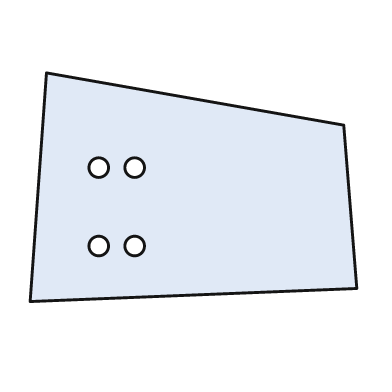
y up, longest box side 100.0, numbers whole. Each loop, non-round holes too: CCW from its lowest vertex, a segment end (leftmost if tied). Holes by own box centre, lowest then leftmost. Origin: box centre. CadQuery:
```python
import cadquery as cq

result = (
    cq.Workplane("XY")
    .moveTo(-50.0, -35.0)
    .lineTo(50.0, -31.0)
    .lineTo(46.0, 19.0)
    .lineTo(-45.0, 35.0)
    .close()
    .moveTo(-29.0, -18.0)
    .circle(3.0)
    .moveTo(-18.0, -18.0)
    .circle(3.0)
    .moveTo(-29.0, 6.0)
    .circle(3.0)
    .moveTo(-18.0, 6.0)
    .circle(3.0)
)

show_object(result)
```